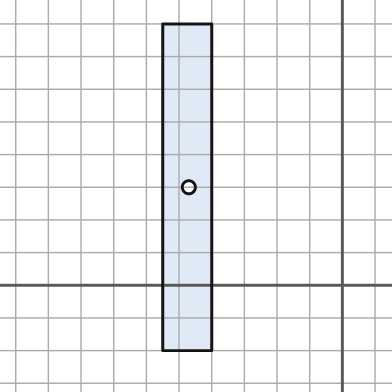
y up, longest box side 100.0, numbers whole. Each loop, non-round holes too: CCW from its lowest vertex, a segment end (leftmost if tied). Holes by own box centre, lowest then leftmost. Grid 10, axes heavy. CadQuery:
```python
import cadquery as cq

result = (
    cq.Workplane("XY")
    .moveTo(-55.0, -20.0)
    .lineTo(-40.0, -20.0)
    .lineTo(-40.0, 80.0)
    .lineTo(-55.0, 80.0)
    .close()
    .moveTo(-47.0, 30.0)
    .circle(2.0)
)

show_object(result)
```